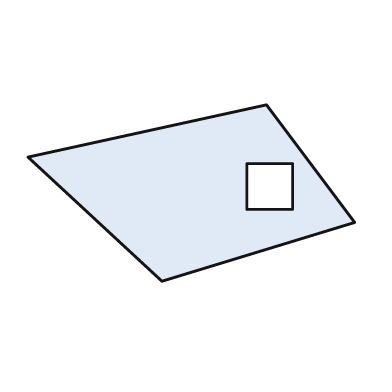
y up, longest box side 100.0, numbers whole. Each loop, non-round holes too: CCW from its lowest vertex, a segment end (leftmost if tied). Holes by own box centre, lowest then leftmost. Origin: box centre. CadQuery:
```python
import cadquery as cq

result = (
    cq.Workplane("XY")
    .moveTo(-9.0, -27.0)
    .lineTo(50.0, -9.0)
    .lineTo(23.0, 27.0)
    .lineTo(-50.0, 11.0)
    .close()
    .moveTo(17.0, -5.0)
    .lineTo(31.0, -5.0)
    .lineTo(31.0, 9.0)
    .lineTo(17.0, 9.0)
    .close()
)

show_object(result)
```